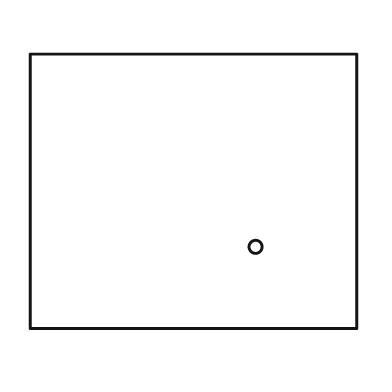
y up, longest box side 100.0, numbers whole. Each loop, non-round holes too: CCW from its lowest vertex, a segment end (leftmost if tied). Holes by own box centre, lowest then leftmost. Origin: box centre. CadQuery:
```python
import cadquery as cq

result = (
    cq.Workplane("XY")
    .moveTo(-50.0, -42.0)
    .lineTo(50.0, -42.0)
    .lineTo(50.0, 42.0)
    .lineTo(-50.0, 42.0)
    .close()
    .moveTo(19.0, -17.0)
    .circle(2.0)
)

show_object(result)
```